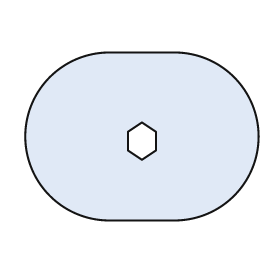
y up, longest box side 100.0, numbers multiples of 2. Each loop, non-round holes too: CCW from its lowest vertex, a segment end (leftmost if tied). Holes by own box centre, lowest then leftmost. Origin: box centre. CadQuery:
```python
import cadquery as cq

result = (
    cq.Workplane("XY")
    .moveTo(-14.0, -36.0)
    .lineTo(14.0, -36.0)
    .threePointArc((50.0, 0.0), (14.0, 36.0))
    .lineTo(-14.0, 36.0)
    .threePointArc((-50.0, 0.0), (-14.0, -36.0))
    .close()
    .moveTo(0.0, -10.0)
    .lineTo(6.0, -6.0)
    .lineTo(6.0, 2.0)
    .lineTo(0.0, 6.0)
    .lineTo(-6.0, 2.0)
    .lineTo(-6.0, -6.0)
    .close()
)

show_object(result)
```